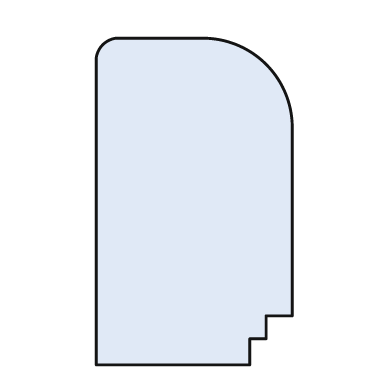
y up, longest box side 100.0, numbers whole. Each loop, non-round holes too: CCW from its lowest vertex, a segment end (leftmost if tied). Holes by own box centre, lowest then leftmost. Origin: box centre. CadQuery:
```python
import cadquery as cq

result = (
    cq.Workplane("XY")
    .moveTo(-30.0, -50.0)
    .lineTo(17.0, -50.0)
    .lineTo(17.0, -42.0)
    .lineTo(22.0, -42.0)
    .lineTo(22.0, -35.0)
    .lineTo(30.0, -35.0)
    .lineTo(30.0, 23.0)
    .threePointArc((22.0, 42.0), (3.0, 50.0))
    .lineTo(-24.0, 50.0)
    .threePointArc((-28.0, 48.0), (-30.0, 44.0))
    .close()
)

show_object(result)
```